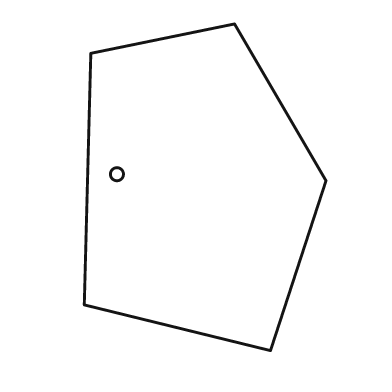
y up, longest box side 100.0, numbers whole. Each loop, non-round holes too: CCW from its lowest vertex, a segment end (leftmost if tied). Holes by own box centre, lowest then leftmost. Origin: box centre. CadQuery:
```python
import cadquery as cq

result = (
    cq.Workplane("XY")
    .moveTo(20.0, -50.0)
    .lineTo(37.0, 2.0)
    .lineTo(9.0, 50.0)
    .lineTo(-35.0, 41.0)
    .lineTo(-37.0, -36.0)
    .close()
    .moveTo(-27.0, 4.0)
    .circle(2.0)
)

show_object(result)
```